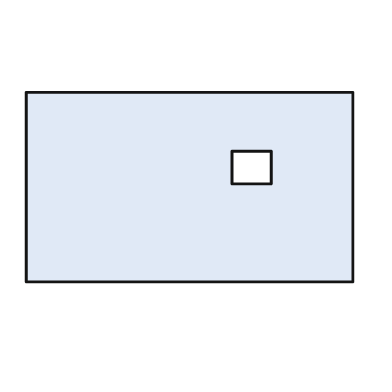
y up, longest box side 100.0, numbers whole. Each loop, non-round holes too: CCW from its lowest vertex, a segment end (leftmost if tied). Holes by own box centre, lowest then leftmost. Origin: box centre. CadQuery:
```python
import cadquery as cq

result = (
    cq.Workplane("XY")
    .moveTo(-50.0, -29.0)
    .lineTo(50.0, -29.0)
    .lineTo(50.0, 29.0)
    .lineTo(-50.0, 29.0)
    .close()
    .moveTo(13.0, 1.0)
    .lineTo(25.0, 1.0)
    .lineTo(25.0, 11.0)
    .lineTo(13.0, 11.0)
    .close()
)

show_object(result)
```